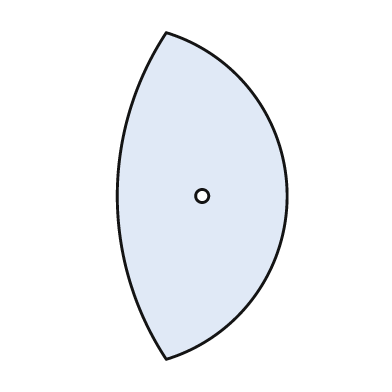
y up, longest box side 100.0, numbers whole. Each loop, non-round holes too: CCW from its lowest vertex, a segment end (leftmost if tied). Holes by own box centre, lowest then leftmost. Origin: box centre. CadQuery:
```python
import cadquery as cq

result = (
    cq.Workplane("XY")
    .moveTo(-11.0, -50.0)
    .threePointArc((26.0, 0.0), (-11.0, 50.0))
    .threePointArc((-26.0, 0.0), (-11.0, -50.0))
    .close()
    .moveTo(0.0, 0.0)
    .circle(2.0)
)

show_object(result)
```